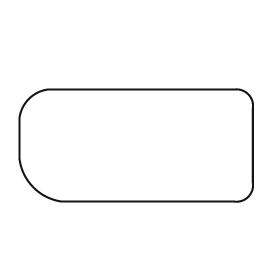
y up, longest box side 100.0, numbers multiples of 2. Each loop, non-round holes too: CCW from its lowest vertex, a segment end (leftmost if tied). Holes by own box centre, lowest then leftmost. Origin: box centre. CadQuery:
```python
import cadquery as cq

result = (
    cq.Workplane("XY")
    .moveTo(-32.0, -24.0)
    .lineTo(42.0, -24.0)
    .threePointArc((48.0, -22.0), (50.0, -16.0))
    .lineTo(50.0, 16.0)
    .threePointArc((48.0, 22.0), (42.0, 24.0))
    .lineTo(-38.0, 24.0)
    .threePointArc((-46.0, 20.0), (-50.0, 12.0))
    .lineTo(-50.0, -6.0)
    .threePointArc((-44.0, -18.0), (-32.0, -24.0))
    .close()
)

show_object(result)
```